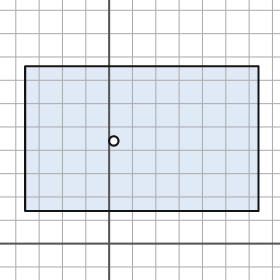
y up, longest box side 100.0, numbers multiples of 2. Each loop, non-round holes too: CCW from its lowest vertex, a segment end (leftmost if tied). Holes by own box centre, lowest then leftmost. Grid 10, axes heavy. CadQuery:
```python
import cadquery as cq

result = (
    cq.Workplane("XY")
    .moveTo(-36.0, 14.0)
    .lineTo(64.0, 14.0)
    .lineTo(64.0, 76.0)
    .lineTo(-36.0, 76.0)
    .close()
    .moveTo(2.0, 44.0)
    .circle(2.0)
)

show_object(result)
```